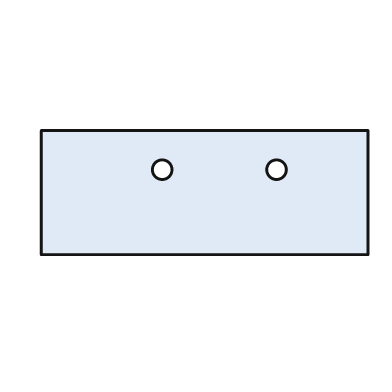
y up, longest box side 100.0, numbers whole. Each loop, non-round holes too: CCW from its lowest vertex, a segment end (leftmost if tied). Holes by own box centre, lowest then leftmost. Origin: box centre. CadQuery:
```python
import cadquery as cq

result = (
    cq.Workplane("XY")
    .moveTo(-50.0, -19.0)
    .lineTo(50.0, -19.0)
    .lineTo(50.0, 19.0)
    .lineTo(-50.0, 19.0)
    .close()
    .moveTo(-13.0, 7.0)
    .circle(3.0)
    .moveTo(22.0, 7.0)
    .circle(3.0)
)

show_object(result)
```